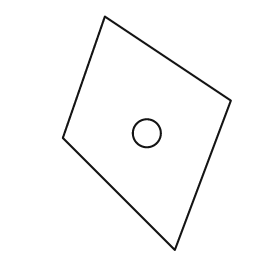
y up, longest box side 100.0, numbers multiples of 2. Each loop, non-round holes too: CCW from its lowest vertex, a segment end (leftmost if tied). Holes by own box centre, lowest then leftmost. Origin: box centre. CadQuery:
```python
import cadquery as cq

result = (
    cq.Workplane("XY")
    .moveTo(12.0, -50.0)
    .lineTo(36.0, 14.0)
    .lineTo(-18.0, 50.0)
    .lineTo(-36.0, -2.0)
    .close()
    .moveTo(0.0, 0.0)
    .circle(6.0)
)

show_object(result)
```